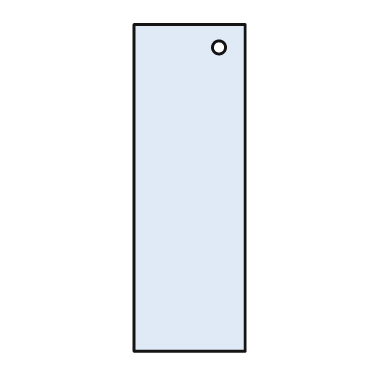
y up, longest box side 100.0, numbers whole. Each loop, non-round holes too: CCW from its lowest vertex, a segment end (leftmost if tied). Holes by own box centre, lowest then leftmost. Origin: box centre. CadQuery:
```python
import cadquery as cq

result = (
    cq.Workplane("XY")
    .moveTo(-17.0, -50.0)
    .lineTo(17.0, -50.0)
    .lineTo(17.0, 50.0)
    .lineTo(-17.0, 50.0)
    .close()
    .moveTo(9.0, 43.0)
    .circle(2.0)
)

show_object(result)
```